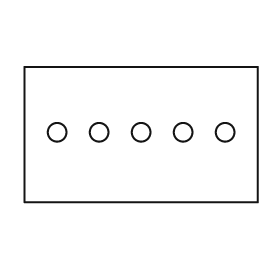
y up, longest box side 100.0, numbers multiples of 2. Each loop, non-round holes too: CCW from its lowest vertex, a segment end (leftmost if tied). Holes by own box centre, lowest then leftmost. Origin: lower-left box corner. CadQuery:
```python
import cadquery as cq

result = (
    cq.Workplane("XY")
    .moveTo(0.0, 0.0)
    .lineTo(100.0, 0.0)
    .lineTo(100.0, 58.0)
    .lineTo(0.0, 58.0)
    .close()
    .moveTo(14.0, 30.0)
    .circle(4.0)
    .moveTo(32.0, 30.0)
    .circle(4.0)
    .moveTo(50.0, 30.0)
    .circle(4.0)
    .moveTo(68.0, 30.0)
    .circle(4.0)
    .moveTo(86.0, 30.0)
    .circle(4.0)
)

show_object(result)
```